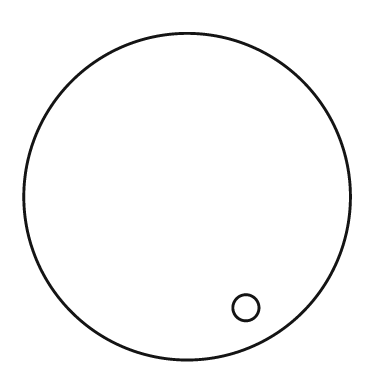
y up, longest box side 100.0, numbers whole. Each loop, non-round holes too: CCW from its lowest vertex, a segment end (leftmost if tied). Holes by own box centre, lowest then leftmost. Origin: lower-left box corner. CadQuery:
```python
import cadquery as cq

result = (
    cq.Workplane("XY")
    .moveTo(50.0, 50.0)
    .circle(50.0)
    .moveTo(68.0, 16.0)
    .circle(4.0)
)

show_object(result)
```